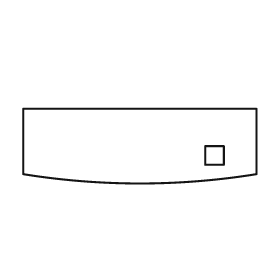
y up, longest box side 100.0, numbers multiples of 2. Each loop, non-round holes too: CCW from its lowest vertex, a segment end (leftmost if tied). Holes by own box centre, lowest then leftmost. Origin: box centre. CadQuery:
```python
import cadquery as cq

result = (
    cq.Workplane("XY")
    .moveTo(-50.0, -12.0)
    .threePointArc((0.0, -16.0), (50.0, -12.0))
    .lineTo(50.0, 16.0)
    .lineTo(-50.0, 16.0)
    .close()
    .moveTo(28.0, -8.0)
    .lineTo(36.0, -8.0)
    .lineTo(36.0, 0.0)
    .lineTo(28.0, 0.0)
    .close()
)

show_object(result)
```